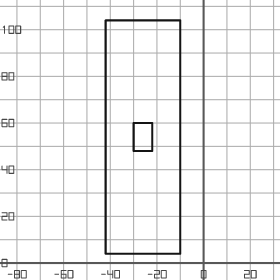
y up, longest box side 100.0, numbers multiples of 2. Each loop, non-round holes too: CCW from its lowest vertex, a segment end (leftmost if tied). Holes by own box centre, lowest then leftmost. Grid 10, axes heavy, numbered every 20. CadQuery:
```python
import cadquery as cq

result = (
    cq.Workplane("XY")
    .moveTo(-42.0, 4.0)
    .lineTo(-10.0, 4.0)
    .lineTo(-10.0, 104.0)
    .lineTo(-42.0, 104.0)
    .close()
    .moveTo(-30.0, 48.0)
    .lineTo(-22.0, 48.0)
    .lineTo(-22.0, 60.0)
    .lineTo(-30.0, 60.0)
    .close()
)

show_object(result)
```